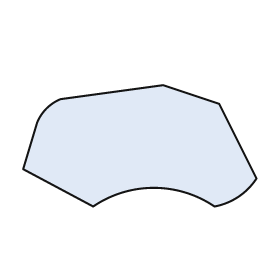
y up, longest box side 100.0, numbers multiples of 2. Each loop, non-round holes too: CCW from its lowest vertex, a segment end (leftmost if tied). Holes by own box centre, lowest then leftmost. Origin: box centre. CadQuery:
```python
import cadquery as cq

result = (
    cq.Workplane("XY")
    .moveTo(-20.0, -26.0)
    .threePointArc((6.0, -18.0), (32.0, -26.0))
    .threePointArc((42.0, -22.0), (50.0, -14.0))
    .lineTo(34.0, 18.0)
    .lineTo(10.0, 26.0)
    .lineTo(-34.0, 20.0)
    .threePointArc((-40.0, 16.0), (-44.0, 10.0))
    .lineTo(-50.0, -10.0)
    .close()
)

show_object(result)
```